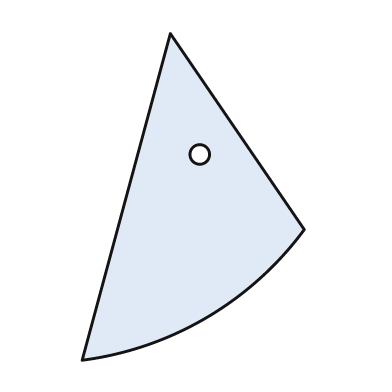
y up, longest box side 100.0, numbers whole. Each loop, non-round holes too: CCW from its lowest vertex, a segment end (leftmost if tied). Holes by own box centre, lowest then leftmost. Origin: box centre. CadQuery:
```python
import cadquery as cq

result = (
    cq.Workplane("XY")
    .moveTo(-34.0, -50.0)
    .threePointArc((4.0, -37.0), (34.0, -10.0))
    .lineTo(-7.0, 50.0)
    .close()
    .moveTo(2.0, 13.0)
    .circle(3.0)
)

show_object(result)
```